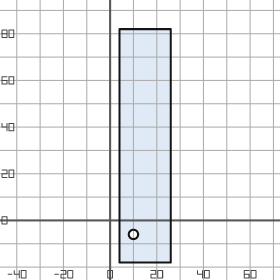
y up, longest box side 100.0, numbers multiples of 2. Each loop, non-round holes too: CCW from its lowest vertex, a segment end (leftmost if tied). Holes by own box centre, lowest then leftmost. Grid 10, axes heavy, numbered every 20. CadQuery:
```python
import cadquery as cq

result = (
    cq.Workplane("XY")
    .moveTo(4.0, -18.0)
    .lineTo(26.0, -18.0)
    .lineTo(26.0, 82.0)
    .lineTo(4.0, 82.0)
    .close()
    .moveTo(10.0, -6.0)
    .circle(2.0)
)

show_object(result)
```